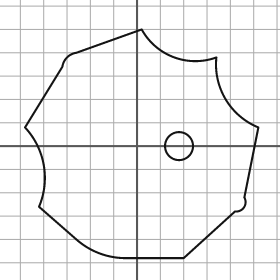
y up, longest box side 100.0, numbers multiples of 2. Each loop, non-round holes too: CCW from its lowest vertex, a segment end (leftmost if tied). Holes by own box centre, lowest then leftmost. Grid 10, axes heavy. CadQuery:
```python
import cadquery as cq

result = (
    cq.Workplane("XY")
    .moveTo(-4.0, -48.0)
    .lineTo(20.0, -48.0)
    .lineTo(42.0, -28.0)
    .threePointArc((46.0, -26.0), (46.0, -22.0))
    .lineTo(52.0, 8.0)
    .threePointArc((38.0, 20.0), (34.0, 38.0))
    .threePointArc((16.0, 38.0), (2.0, 50.0))
    .lineTo(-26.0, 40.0)
    .threePointArc((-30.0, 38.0), (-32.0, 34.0))
    .lineTo(-48.0, 8.0)
    .threePointArc((-40.0, -8.0), (-42.0, -26.0))
    .lineTo(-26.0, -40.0)
    .threePointArc((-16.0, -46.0), (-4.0, -48.0))
    .close()
    .moveTo(18.0, 0.0)
    .circle(6.0)
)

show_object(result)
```